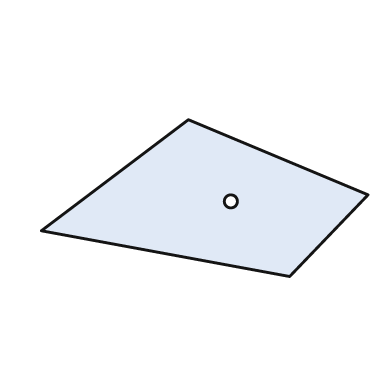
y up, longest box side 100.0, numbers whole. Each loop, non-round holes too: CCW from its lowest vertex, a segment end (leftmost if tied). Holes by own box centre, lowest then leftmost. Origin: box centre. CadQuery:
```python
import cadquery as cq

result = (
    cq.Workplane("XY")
    .moveTo(26.0, -24.0)
    .lineTo(50.0, 1.0)
    .lineTo(-5.0, 24.0)
    .lineTo(-50.0, -10.0)
    .close()
    .moveTo(8.0, -1.0)
    .circle(2.0)
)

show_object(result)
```